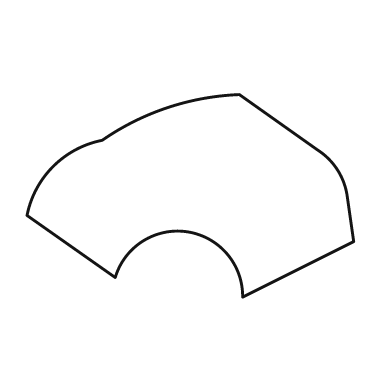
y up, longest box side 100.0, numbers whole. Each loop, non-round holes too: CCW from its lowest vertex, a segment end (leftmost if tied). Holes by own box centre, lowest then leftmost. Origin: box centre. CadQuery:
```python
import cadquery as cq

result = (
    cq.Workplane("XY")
    .moveTo(16.0, -31.0)
    .lineTo(50.0, -14.0)
    .lineTo(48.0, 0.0)
    .threePointArc((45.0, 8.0), (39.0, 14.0))
    .lineTo(15.0, 31.0)
    .threePointArc((-7.0, 27.0), (-27.0, 17.0))
    .threePointArc((-42.0, 9.0), (-50.0, -6.0))
    .lineTo(-23.0, -25.0)
    .threePointArc((-1.0, -11.0), (16.0, -31.0))
    .close()
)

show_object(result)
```